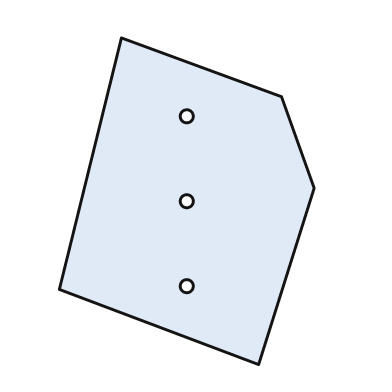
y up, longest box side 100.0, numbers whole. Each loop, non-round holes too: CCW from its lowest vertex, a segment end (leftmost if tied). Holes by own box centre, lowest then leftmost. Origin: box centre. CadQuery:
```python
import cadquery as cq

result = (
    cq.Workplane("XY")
    .moveTo(22.0, -50.0)
    .lineTo(39.0, 4.0)
    .lineTo(29.0, 32.0)
    .lineTo(-20.0, 50.0)
    .lineTo(-39.0, -27.0)
    .close()
    .moveTo(0.0, -26.0)
    .circle(2.0)
    .moveTo(0.0, 0.0)
    .circle(2.0)
    .moveTo(0.0, 26.0)
    .circle(2.0)
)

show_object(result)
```